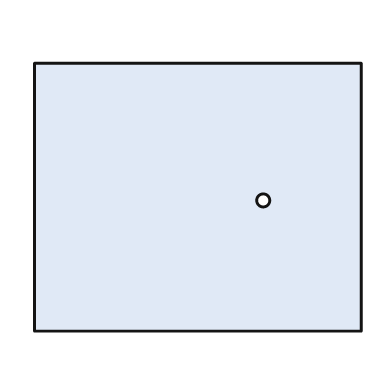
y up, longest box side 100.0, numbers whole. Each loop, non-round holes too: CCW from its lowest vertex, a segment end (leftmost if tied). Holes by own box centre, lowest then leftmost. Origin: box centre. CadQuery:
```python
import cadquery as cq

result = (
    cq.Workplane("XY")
    .moveTo(-50.0, -41.0)
    .lineTo(50.0, -41.0)
    .lineTo(50.0, 41.0)
    .lineTo(-50.0, 41.0)
    .close()
    .moveTo(20.0, -1.0)
    .circle(2.0)
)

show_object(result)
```